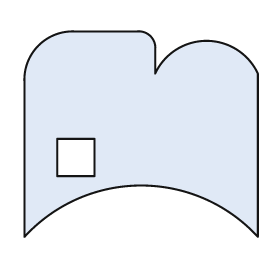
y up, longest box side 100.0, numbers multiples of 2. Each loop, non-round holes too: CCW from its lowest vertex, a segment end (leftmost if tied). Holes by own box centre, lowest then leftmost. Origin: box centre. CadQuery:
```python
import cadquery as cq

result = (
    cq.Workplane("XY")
    .moveTo(-50.0, -44.0)
    .threePointArc((0.0, -22.0), (50.0, -44.0))
    .lineTo(50.0, 26.0)
    .threePointArc((28.0, 40.0), (6.0, 26.0))
    .lineTo(6.0, 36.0)
    .threePointArc((4.0, 42.0), (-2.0, 44.0))
    .lineTo(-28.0, 44.0)
    .threePointArc((-44.0, 38.0), (-50.0, 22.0))
    .close()
    .moveTo(-36.0, -18.0)
    .lineTo(-20.0, -18.0)
    .lineTo(-20.0, -2.0)
    .lineTo(-36.0, -2.0)
    .close()
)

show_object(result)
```